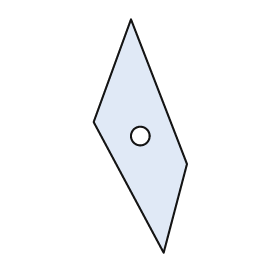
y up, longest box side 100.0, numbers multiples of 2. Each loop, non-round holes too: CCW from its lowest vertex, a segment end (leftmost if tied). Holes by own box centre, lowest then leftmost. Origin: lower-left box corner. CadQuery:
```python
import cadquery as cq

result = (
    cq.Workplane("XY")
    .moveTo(30.0, 0.0)
    .lineTo(40.0, 38.0)
    .lineTo(16.0, 100.0)
    .lineTo(0.0, 56.0)
    .close()
    .moveTo(20.0, 50.0)
    .circle(4.0)
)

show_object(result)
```